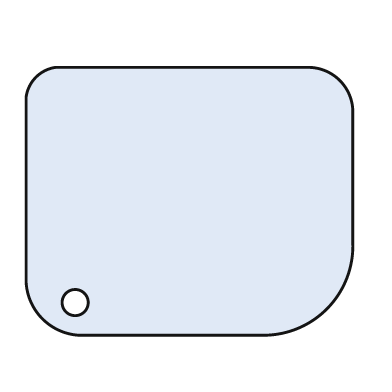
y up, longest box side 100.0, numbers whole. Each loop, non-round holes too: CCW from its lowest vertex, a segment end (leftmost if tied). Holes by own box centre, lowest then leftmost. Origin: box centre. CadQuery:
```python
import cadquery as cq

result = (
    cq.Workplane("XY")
    .moveTo(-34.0, -41.0)
    .lineTo(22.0, -41.0)
    .threePointArc((42.0, -33.0), (50.0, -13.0))
    .lineTo(50.0, 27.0)
    .threePointArc((46.0, 37.0), (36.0, 41.0))
    .lineTo(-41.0, 41.0)
    .threePointArc((-47.0, 38.0), (-50.0, 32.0))
    .lineTo(-50.0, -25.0)
    .threePointArc((-45.0, -36.0), (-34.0, -41.0))
    .close()
    .moveTo(-35.0, -31.0)
    .circle(4.0)
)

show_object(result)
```